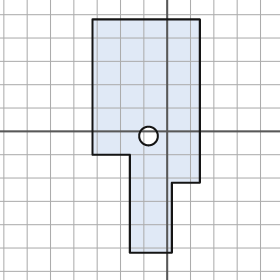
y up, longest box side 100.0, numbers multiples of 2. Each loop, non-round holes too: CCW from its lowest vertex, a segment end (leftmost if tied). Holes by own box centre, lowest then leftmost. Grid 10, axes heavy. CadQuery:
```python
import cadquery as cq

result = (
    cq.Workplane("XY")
    .moveTo(-16.0, -52.0)
    .lineTo(2.0, -52.0)
    .lineTo(2.0, -22.0)
    .lineTo(14.0, -22.0)
    .lineTo(14.0, 48.0)
    .lineTo(-32.0, 48.0)
    .lineTo(-32.0, -10.0)
    .lineTo(-16.0, -10.0)
    .close()
    .moveTo(-8.0, -2.0)
    .circle(4.0)
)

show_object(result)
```